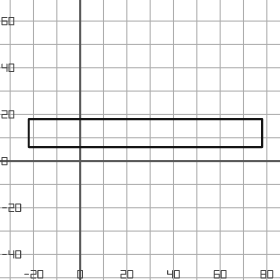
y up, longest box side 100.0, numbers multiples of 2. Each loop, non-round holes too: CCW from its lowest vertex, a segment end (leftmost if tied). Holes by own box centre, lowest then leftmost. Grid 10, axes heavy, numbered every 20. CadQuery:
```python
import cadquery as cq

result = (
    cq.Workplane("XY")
    .moveTo(-22.0, 6.0)
    .lineTo(78.0, 6.0)
    .lineTo(78.0, 18.0)
    .lineTo(-22.0, 18.0)
    .close()
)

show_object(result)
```